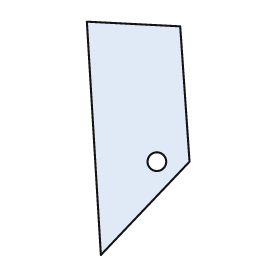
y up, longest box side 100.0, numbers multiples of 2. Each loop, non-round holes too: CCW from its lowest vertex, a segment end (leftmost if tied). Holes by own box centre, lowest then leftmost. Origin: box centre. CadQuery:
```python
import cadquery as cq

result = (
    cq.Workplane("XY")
    .moveTo(-16.0, -50.0)
    .lineTo(22.0, -10.0)
    .lineTo(18.0, 48.0)
    .lineTo(-22.0, 50.0)
    .close()
    .moveTo(8.0, -10.0)
    .circle(4.0)
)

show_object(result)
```